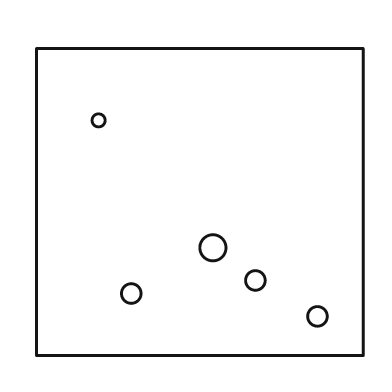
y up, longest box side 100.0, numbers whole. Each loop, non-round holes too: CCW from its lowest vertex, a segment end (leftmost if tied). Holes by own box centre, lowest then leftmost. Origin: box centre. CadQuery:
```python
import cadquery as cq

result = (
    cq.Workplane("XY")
    .moveTo(-50.0, -47.0)
    .lineTo(50.0, -47.0)
    .lineTo(50.0, 47.0)
    .lineTo(-50.0, 47.0)
    .close()
    .moveTo(36.0, -35.0)
    .circle(3.0)
    .moveTo(-21.0, -28.0)
    .circle(3.0)
    .moveTo(17.0, -24.0)
    .circle(3.0)
    .moveTo(4.0, -14.0)
    .circle(4.0)
    .moveTo(-31.0, 25.0)
    .circle(2.0)
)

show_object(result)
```